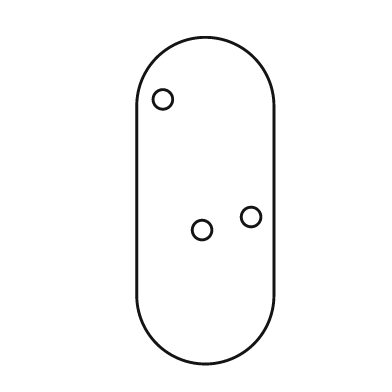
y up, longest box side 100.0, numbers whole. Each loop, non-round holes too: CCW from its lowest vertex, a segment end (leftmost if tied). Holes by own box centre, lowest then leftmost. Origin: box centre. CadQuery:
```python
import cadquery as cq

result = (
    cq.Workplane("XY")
    .moveTo(-21.0, -29.0)
    .threePointArc((0.0, -50.0), (21.0, -29.0))
    .lineTo(21.0, 29.0)
    .threePointArc((0.0, 50.0), (-21.0, 29.0))
    .close()
    .moveTo(-1.0, -9.0)
    .circle(3.0)
    .moveTo(14.0, -5.0)
    .circle(3.0)
    .moveTo(-13.0, 31.0)
    .circle(3.0)
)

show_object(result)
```